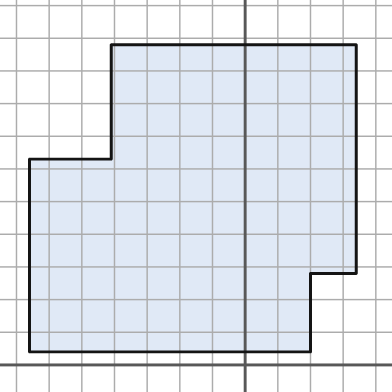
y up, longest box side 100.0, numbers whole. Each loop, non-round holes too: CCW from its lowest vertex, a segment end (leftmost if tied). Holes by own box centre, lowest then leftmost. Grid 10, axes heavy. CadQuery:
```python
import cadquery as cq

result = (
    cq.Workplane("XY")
    .moveTo(-66.0, 4.0)
    .lineTo(20.0, 4.0)
    .lineTo(20.0, 28.0)
    .lineTo(34.0, 28.0)
    .lineTo(34.0, 98.0)
    .lineTo(-41.0, 98.0)
    .lineTo(-41.0, 63.0)
    .lineTo(-66.0, 63.0)
    .close()
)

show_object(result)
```